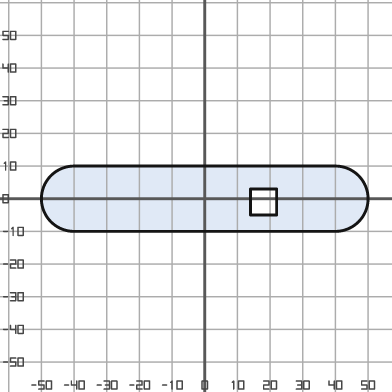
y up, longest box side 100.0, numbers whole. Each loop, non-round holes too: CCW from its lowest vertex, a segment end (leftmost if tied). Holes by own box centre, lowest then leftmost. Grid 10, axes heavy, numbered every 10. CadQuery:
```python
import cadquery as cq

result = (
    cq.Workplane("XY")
    .moveTo(-40.0, -10.0)
    .lineTo(40.0, -10.0)
    .threePointArc((50.0, 0.0), (40.0, 10.0))
    .lineTo(-40.0, 10.0)
    .threePointArc((-50.0, 0.0), (-40.0, -10.0))
    .close()
    .moveTo(14.0, -5.0)
    .lineTo(22.0, -5.0)
    .lineTo(22.0, 3.0)
    .lineTo(14.0, 3.0)
    .close()
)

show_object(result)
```